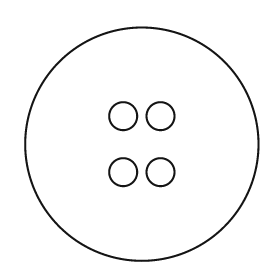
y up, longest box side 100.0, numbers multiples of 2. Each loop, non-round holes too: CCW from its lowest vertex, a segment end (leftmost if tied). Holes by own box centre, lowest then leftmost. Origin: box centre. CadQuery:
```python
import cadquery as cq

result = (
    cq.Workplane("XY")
    .moveTo(0.0, 0.0)
    .circle(50.0)
    .moveTo(-8.0, -12.0)
    .circle(6.0)
    .moveTo(8.0, -12.0)
    .circle(6.0)
    .moveTo(-8.0, 12.0)
    .circle(6.0)
    .moveTo(8.0, 12.0)
    .circle(6.0)
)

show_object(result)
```